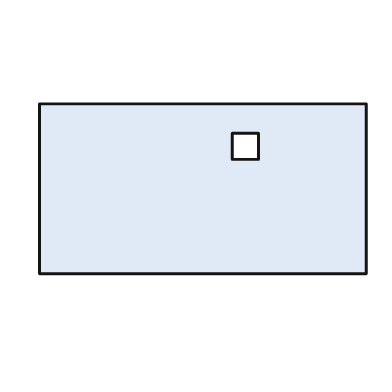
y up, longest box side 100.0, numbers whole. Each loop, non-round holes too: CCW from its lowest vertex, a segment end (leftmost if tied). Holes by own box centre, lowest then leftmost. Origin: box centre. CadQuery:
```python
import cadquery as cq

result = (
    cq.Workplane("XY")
    .moveTo(-50.0, -26.0)
    .lineTo(50.0, -26.0)
    .lineTo(50.0, 26.0)
    .lineTo(-50.0, 26.0)
    .close()
    .moveTo(9.0, 9.0)
    .lineTo(17.0, 9.0)
    .lineTo(17.0, 17.0)
    .lineTo(9.0, 17.0)
    .close()
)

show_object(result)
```